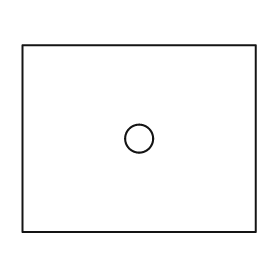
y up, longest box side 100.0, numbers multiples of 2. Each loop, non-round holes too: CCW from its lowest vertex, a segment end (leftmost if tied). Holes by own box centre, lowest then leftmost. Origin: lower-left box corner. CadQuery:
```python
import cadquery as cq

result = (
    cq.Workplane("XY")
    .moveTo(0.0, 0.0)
    .lineTo(100.0, 0.0)
    .lineTo(100.0, 80.0)
    .lineTo(0.0, 80.0)
    .close()
    .moveTo(50.0, 40.0)
    .circle(6.0)
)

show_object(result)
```